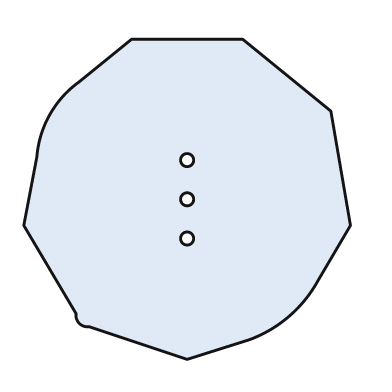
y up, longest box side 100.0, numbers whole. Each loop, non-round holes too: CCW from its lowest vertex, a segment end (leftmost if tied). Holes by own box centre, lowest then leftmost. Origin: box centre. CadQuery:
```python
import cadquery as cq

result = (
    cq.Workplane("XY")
    .moveTo(0.0, -49.0)
    .lineTo(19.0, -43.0)
    .threePointArc((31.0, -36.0), (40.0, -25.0))
    .lineTo(50.0, -8.0)
    .lineTo(44.0, 27.0)
    .lineTo(17.0, 49.0)
    .lineTo(-17.0, 49.0)
    .lineTo(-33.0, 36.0)
    .threePointArc((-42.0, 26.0), (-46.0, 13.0))
    .lineTo(-50.0, -8.0)
    .lineTo(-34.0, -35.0)
    .threePointArc((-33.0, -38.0), (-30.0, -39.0))
    .close()
    .moveTo(0.0, -12.0)
    .circle(2.0)
    .moveTo(0.0, 0.0)
    .circle(2.0)
    .moveTo(0.0, 12.0)
    .circle(2.0)
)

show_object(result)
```